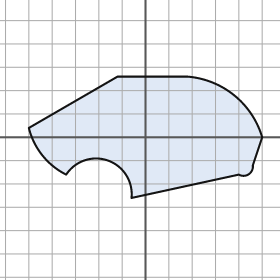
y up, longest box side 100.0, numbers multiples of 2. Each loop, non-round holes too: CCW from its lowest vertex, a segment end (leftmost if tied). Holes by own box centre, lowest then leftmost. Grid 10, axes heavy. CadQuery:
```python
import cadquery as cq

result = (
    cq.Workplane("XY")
    .moveTo(-6.0, -26.0)
    .lineTo(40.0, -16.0)
    .threePointArc((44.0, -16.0), (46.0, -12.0))
    .lineTo(50.0, 0.0)
    .threePointArc((38.0, 18.0), (18.0, 26.0))
    .lineTo(-12.0, 26.0)
    .lineTo(-50.0, 4.0)
    .threePointArc((-44.0, -8.0), (-34.0, -16.0))
    .threePointArc((-16.0, -10.0), (-6.0, -26.0))
    .close()
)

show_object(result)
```